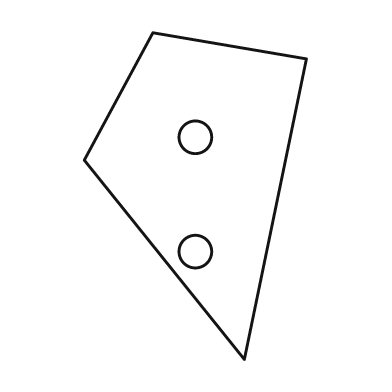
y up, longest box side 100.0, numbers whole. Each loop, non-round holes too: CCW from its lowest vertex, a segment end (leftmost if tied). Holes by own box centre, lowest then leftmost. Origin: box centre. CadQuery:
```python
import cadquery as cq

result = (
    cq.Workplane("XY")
    .moveTo(15.0, -50.0)
    .lineTo(34.0, 42.0)
    .lineTo(-13.0, 50.0)
    .lineTo(-34.0, 11.0)
    .close()
    .moveTo(0.0, -17.0)
    .circle(5.0)
    .moveTo(0.0, 18.0)
    .circle(5.0)
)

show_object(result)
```